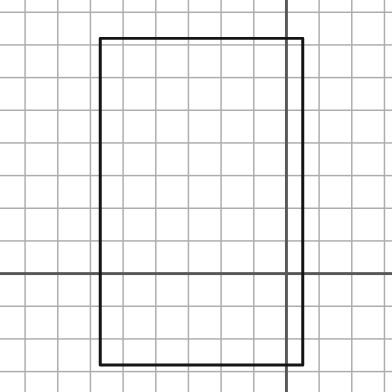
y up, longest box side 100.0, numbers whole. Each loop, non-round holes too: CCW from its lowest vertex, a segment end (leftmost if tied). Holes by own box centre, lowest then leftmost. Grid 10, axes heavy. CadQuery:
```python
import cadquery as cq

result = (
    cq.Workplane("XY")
    .moveTo(-57.0, -28.0)
    .lineTo(5.0, -28.0)
    .lineTo(5.0, 72.0)
    .lineTo(-57.0, 72.0)
    .close()
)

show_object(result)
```